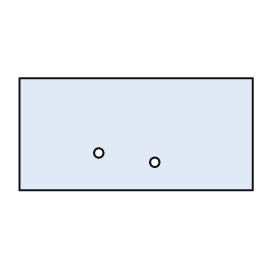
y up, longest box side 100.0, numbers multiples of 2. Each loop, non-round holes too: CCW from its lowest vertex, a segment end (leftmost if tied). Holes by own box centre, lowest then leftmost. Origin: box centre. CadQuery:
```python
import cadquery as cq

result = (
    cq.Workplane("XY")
    .moveTo(-50.0, -24.0)
    .lineTo(50.0, -24.0)
    .lineTo(50.0, 24.0)
    .lineTo(-50.0, 24.0)
    .close()
    .moveTo(8.0, -12.0)
    .circle(2.0)
    .moveTo(-16.0, -8.0)
    .circle(2.0)
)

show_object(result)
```